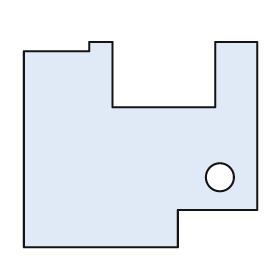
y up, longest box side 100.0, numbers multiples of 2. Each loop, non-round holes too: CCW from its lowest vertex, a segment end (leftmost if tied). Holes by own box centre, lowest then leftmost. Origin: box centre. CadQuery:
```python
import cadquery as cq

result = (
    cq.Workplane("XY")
    .moveTo(-50.0, -44.0)
    .lineTo(16.0, -44.0)
    .lineTo(16.0, -28.0)
    .lineTo(50.0, -28.0)
    .lineTo(50.0, 44.0)
    .lineTo(32.0, 44.0)
    .lineTo(32.0, 16.0)
    .lineTo(-12.0, 16.0)
    .lineTo(-12.0, 44.0)
    .lineTo(-22.0, 44.0)
    .lineTo(-22.0, 40.0)
    .lineTo(-50.0, 40.0)
    .close()
    .moveTo(34.0, -14.0)
    .circle(6.0)
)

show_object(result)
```